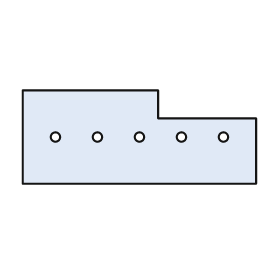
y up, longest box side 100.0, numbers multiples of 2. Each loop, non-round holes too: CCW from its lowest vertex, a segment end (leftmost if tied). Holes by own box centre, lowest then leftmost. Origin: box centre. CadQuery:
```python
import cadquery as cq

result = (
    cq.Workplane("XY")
    .moveTo(-50.0, -20.0)
    .lineTo(50.0, -20.0)
    .lineTo(50.0, 8.0)
    .lineTo(8.0, 8.0)
    .lineTo(8.0, 20.0)
    .lineTo(-50.0, 20.0)
    .close()
    .moveTo(-36.0, 0.0)
    .circle(2.0)
    .moveTo(-18.0, 0.0)
    .circle(2.0)
    .moveTo(0.0, 0.0)
    .circle(2.0)
    .moveTo(18.0, 0.0)
    .circle(2.0)
    .moveTo(36.0, 0.0)
    .circle(2.0)
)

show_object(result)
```